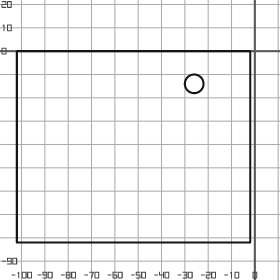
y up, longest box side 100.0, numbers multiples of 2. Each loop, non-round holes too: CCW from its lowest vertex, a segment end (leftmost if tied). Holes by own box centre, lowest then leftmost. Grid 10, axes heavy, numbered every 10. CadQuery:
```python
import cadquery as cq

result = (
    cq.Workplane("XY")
    .moveTo(-102.0, -82.0)
    .lineTo(-2.0, -82.0)
    .lineTo(-2.0, 0.0)
    .lineTo(-102.0, 0.0)
    .close()
    .moveTo(-26.0, -14.0)
    .circle(4.0)
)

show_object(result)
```